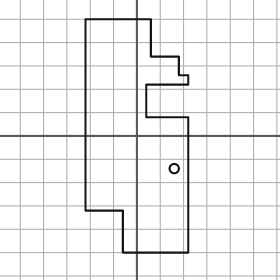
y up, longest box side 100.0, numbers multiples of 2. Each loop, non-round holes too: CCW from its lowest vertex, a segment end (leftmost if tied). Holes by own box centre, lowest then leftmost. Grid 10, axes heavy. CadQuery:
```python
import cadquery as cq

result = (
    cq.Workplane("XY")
    .moveTo(-6.0, -50.0)
    .lineTo(22.0, -50.0)
    .lineTo(22.0, 8.0)
    .lineTo(4.0, 8.0)
    .lineTo(4.0, 22.0)
    .lineTo(22.0, 22.0)
    .lineTo(22.0, 26.0)
    .lineTo(18.0, 26.0)
    .lineTo(18.0, 34.0)
    .lineTo(6.0, 34.0)
    .lineTo(6.0, 50.0)
    .lineTo(-22.0, 50.0)
    .lineTo(-22.0, -32.0)
    .lineTo(-6.0, -32.0)
    .close()
    .moveTo(16.0, -14.0)
    .circle(2.0)
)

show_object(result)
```